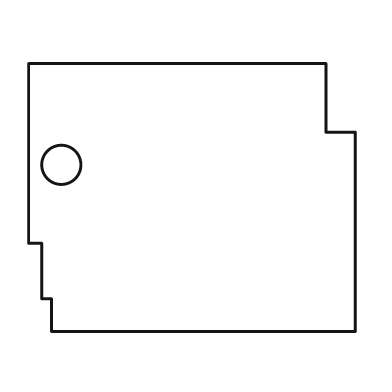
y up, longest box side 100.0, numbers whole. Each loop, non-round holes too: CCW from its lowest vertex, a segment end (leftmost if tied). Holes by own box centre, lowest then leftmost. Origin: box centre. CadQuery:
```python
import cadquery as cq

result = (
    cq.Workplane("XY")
    .moveTo(-43.0, -41.0)
    .lineTo(50.0, -41.0)
    .lineTo(50.0, 20.0)
    .lineTo(41.0, 20.0)
    .lineTo(41.0, 41.0)
    .lineTo(-50.0, 41.0)
    .lineTo(-50.0, -14.0)
    .lineTo(-46.0, -14.0)
    .lineTo(-46.0, -31.0)
    .lineTo(-43.0, -31.0)
    .close()
    .moveTo(-40.0, 10.0)
    .circle(6.0)
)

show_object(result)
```